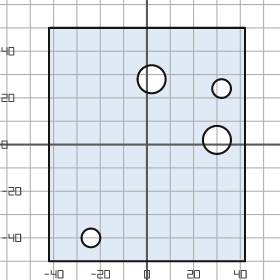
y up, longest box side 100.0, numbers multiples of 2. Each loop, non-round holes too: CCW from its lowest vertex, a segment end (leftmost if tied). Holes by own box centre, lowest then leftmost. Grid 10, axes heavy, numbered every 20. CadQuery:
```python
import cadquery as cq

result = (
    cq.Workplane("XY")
    .moveTo(-42.0, -50.0)
    .lineTo(42.0, -50.0)
    .lineTo(42.0, 50.0)
    .lineTo(-42.0, 50.0)
    .close()
    .moveTo(-24.0, -40.0)
    .circle(4.0)
    .moveTo(30.0, 2.0)
    .circle(6.0)
    .moveTo(32.0, 24.0)
    .circle(4.0)
    .moveTo(2.0, 28.0)
    .circle(6.0)
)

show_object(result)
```